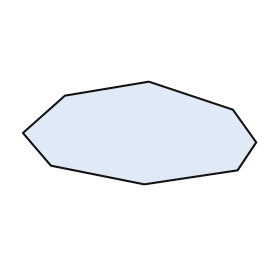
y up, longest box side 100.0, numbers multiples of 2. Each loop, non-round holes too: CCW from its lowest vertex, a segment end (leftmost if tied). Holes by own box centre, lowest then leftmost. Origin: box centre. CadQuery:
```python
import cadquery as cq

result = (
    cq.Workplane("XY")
    .moveTo(2.0, -22.0)
    .lineTo(42.0, -16.0)
    .lineTo(50.0, -4.0)
    .lineTo(40.0, 10.0)
    .lineTo(4.0, 22.0)
    .lineTo(-32.0, 16.0)
    .lineTo(-50.0, 0.0)
    .lineTo(-38.0, -14.0)
    .close()
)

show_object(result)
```